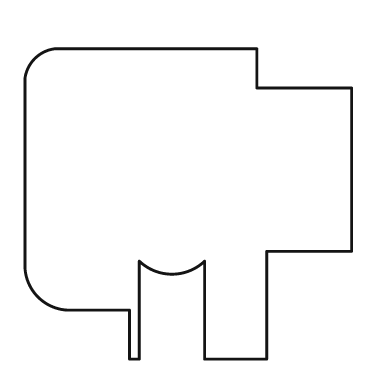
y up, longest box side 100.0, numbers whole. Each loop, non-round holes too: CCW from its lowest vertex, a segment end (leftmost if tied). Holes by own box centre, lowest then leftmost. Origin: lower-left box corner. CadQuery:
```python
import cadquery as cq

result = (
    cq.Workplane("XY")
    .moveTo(32.0, 0.0)
    .lineTo(35.0, 0.0)
    .lineTo(35.0, 30.0)
    .threePointArc((45.0, 26.0), (55.0, 30.0))
    .lineTo(55.0, 0.0)
    .lineTo(74.0, 0.0)
    .lineTo(74.0, 33.0)
    .lineTo(100.0, 33.0)
    .lineTo(100.0, 83.0)
    .lineTo(71.0, 83.0)
    .lineTo(71.0, 95.0)
    .lineTo(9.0, 95.0)
    .threePointArc((3.0, 92.0), (0.0, 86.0))
    .lineTo(0.0, 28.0)
    .threePointArc((4.0, 19.0), (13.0, 15.0))
    .lineTo(32.0, 15.0)
    .close()
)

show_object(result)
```